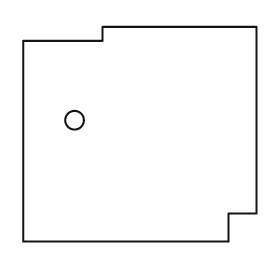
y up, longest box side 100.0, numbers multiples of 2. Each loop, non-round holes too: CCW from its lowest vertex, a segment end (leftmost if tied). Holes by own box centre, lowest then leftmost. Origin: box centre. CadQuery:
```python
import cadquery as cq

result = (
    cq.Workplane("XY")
    .moveTo(-50.0, -46.0)
    .lineTo(38.0, -46.0)
    .lineTo(38.0, -34.0)
    .lineTo(50.0, -34.0)
    .lineTo(50.0, 46.0)
    .lineTo(-16.0, 46.0)
    .lineTo(-16.0, 40.0)
    .lineTo(-50.0, 40.0)
    .close()
    .moveTo(-28.0, 6.0)
    .circle(4.0)
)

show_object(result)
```